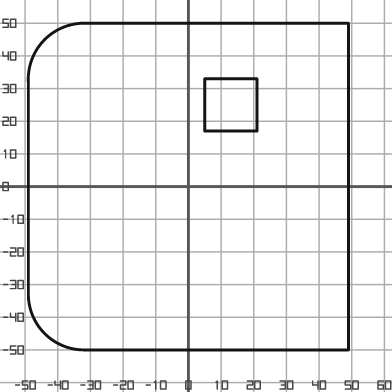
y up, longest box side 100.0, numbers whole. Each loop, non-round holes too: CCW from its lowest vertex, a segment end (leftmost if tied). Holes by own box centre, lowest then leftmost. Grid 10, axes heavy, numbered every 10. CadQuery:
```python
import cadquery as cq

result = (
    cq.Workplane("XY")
    .moveTo(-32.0, -50.0)
    .lineTo(49.0, -50.0)
    .lineTo(49.0, 50.0)
    .lineTo(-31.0, 50.0)
    .threePointArc((-44.0, 45.0), (-49.0, 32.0))
    .lineTo(-49.0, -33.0)
    .threePointArc((-44.0, -45.0), (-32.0, -50.0))
    .close()
    .moveTo(5.0, 17.0)
    .lineTo(21.0, 17.0)
    .lineTo(21.0, 33.0)
    .lineTo(5.0, 33.0)
    .close()
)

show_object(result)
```